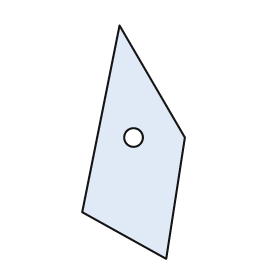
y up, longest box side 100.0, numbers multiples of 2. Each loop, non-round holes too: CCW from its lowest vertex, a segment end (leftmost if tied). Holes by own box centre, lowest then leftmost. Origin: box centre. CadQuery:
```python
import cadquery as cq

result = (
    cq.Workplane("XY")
    .moveTo(14.0, -50.0)
    .lineTo(22.0, 2.0)
    .lineTo(-6.0, 50.0)
    .lineTo(-22.0, -30.0)
    .close()
    .moveTo(0.0, 2.0)
    .circle(4.0)
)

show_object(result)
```